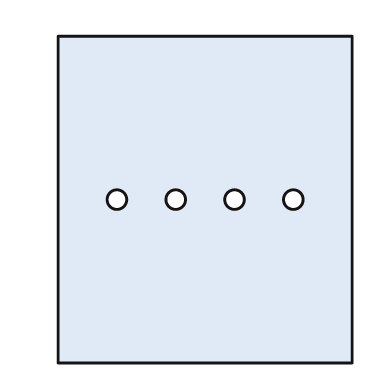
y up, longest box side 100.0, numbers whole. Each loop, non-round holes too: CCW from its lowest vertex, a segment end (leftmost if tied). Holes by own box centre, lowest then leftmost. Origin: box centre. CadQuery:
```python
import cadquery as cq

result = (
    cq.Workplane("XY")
    .moveTo(-45.0, -50.0)
    .lineTo(45.0, -50.0)
    .lineTo(45.0, 50.0)
    .lineTo(-45.0, 50.0)
    .close()
    .moveTo(-27.0, 0.0)
    .circle(3.0)
    .moveTo(-9.0, 0.0)
    .circle(3.0)
    .moveTo(9.0, 0.0)
    .circle(3.0)
    .moveTo(27.0, 0.0)
    .circle(3.0)
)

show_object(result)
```